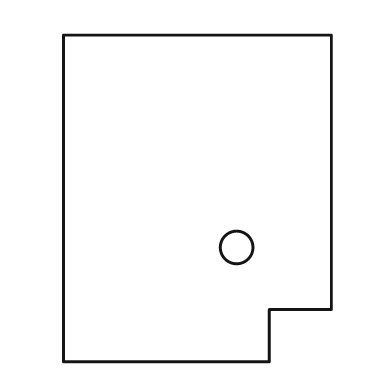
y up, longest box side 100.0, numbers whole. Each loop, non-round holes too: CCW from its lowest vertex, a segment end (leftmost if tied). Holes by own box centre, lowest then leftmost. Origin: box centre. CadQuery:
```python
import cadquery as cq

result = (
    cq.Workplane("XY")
    .moveTo(-41.0, -50.0)
    .lineTo(22.0, -50.0)
    .lineTo(22.0, -34.0)
    .lineTo(41.0, -34.0)
    .lineTo(41.0, 50.0)
    .lineTo(-41.0, 50.0)
    .close()
    .moveTo(12.0, -15.0)
    .circle(5.0)
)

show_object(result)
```